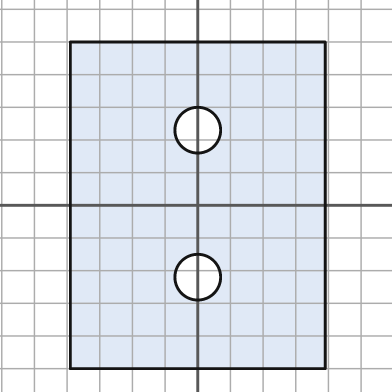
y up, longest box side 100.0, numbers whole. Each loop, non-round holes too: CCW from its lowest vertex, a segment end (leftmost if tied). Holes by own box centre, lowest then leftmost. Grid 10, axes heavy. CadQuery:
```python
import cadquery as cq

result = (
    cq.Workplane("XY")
    .moveTo(-39.0, -50.0)
    .lineTo(39.0, -50.0)
    .lineTo(39.0, 50.0)
    .lineTo(-39.0, 50.0)
    .close()
    .moveTo(0.0, -22.0)
    .circle(7.0)
    .moveTo(0.0, 23.0)
    .circle(7.0)
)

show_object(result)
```